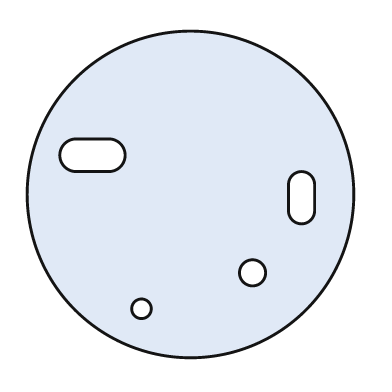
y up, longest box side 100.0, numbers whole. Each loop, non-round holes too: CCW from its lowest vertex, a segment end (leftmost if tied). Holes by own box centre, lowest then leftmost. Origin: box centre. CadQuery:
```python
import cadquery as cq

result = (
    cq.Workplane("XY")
    .moveTo(0.0, 0.0)
    .circle(50.0)
    .moveTo(-15.0, -35.0)
    .circle(3.0)
    .moveTo(19.0, -24.0)
    .circle(4.0)
    .moveTo(30.0, -5.0)
    .threePointArc((34.0, -9.0), (38.0, -5.0))
    .lineTo(38.0, 3.0)
    .threePointArc((34.0, 7.0), (30.0, 3.0))
    .close()
    .moveTo(-35.0, 7.0)
    .lineTo(-25.0, 7.0)
    .threePointArc((-20.0, 12.0), (-25.0, 17.0))
    .lineTo(-35.0, 17.0)
    .threePointArc((-40.0, 12.0), (-35.0, 7.0))
    .close()
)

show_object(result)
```